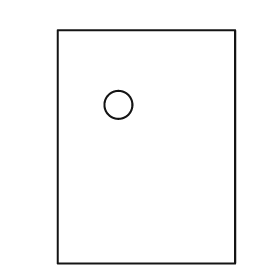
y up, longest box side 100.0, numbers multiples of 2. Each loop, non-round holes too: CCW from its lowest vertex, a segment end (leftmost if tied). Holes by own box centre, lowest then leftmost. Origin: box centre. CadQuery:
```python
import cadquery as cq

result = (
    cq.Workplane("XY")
    .moveTo(-38.0, -50.0)
    .lineTo(38.0, -50.0)
    .lineTo(38.0, 50.0)
    .lineTo(-38.0, 50.0)
    .close()
    .moveTo(-12.0, 18.0)
    .circle(6.0)
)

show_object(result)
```